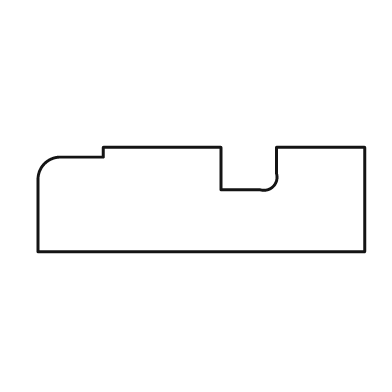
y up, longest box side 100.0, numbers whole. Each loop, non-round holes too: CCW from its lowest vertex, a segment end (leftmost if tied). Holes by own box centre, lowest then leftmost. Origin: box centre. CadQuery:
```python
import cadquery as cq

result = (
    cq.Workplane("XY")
    .moveTo(-50.0, -16.0)
    .lineTo(50.0, -16.0)
    .lineTo(50.0, 16.0)
    .lineTo(23.0, 16.0)
    .lineTo(23.0, 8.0)
    .threePointArc((22.0, 4.0), (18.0, 3.0))
    .lineTo(6.0, 3.0)
    .lineTo(6.0, 16.0)
    .lineTo(-30.0, 16.0)
    .lineTo(-30.0, 13.0)
    .lineTo(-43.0, 13.0)
    .threePointArc((-48.0, 11.0), (-50.0, 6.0))
    .close()
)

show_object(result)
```